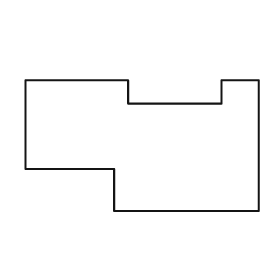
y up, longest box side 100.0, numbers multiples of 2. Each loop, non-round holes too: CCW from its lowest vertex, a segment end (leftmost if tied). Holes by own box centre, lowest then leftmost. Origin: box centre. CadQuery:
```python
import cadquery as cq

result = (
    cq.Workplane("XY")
    .moveTo(-12.0, -28.0)
    .lineTo(50.0, -28.0)
    .lineTo(50.0, 28.0)
    .lineTo(34.0, 28.0)
    .lineTo(34.0, 18.0)
    .lineTo(-6.0, 18.0)
    .lineTo(-6.0, 28.0)
    .lineTo(-50.0, 28.0)
    .lineTo(-50.0, -10.0)
    .lineTo(-12.0, -10.0)
    .close()
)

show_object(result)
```